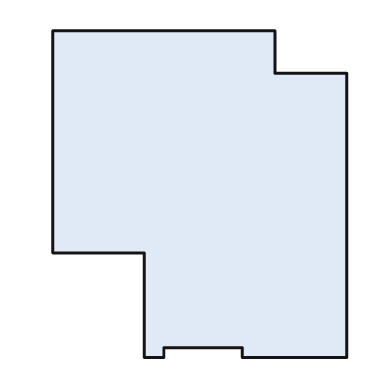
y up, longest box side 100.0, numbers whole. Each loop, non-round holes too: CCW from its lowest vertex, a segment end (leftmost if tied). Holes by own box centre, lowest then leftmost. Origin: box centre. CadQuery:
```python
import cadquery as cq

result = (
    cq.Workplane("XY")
    .moveTo(-17.0, -50.0)
    .lineTo(-11.0, -50.0)
    .lineTo(-11.0, -47.0)
    .lineTo(13.0, -47.0)
    .lineTo(13.0, -50.0)
    .lineTo(45.0, -50.0)
    .lineTo(45.0, 37.0)
    .lineTo(23.0, 37.0)
    .lineTo(23.0, 50.0)
    .lineTo(-45.0, 50.0)
    .lineTo(-45.0, -18.0)
    .lineTo(-17.0, -18.0)
    .close()
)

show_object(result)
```